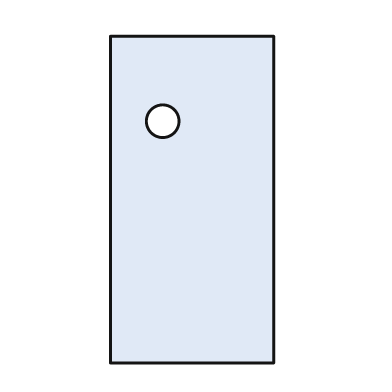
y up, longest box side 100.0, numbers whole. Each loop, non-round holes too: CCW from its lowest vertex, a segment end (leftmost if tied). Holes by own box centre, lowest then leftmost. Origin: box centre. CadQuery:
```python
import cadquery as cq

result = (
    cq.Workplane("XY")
    .moveTo(-25.0, -50.0)
    .lineTo(25.0, -50.0)
    .lineTo(25.0, 50.0)
    .lineTo(-25.0, 50.0)
    .close()
    .moveTo(-9.0, 24.0)
    .circle(5.0)
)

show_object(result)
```